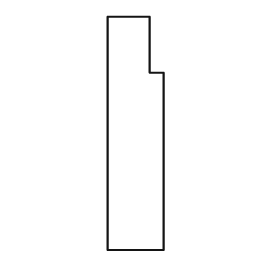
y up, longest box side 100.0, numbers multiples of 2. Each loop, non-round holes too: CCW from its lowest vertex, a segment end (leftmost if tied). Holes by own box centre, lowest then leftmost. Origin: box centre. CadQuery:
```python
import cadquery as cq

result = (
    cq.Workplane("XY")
    .moveTo(-12.0, -50.0)
    .lineTo(12.0, -50.0)
    .lineTo(12.0, 26.0)
    .lineTo(6.0, 26.0)
    .lineTo(6.0, 50.0)
    .lineTo(-12.0, 50.0)
    .close()
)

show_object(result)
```